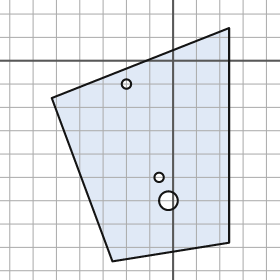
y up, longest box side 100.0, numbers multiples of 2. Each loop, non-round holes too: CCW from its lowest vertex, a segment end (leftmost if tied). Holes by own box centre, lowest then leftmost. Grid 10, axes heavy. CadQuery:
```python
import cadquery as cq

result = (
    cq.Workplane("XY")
    .moveTo(-26.0, -86.0)
    .lineTo(24.0, -78.0)
    .lineTo(24.0, 14.0)
    .lineTo(-52.0, -16.0)
    .close()
    .moveTo(-2.0, -60.0)
    .circle(4.0)
    .moveTo(-6.0, -50.0)
    .circle(2.0)
    .moveTo(-20.0, -10.0)
    .circle(2.0)
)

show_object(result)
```